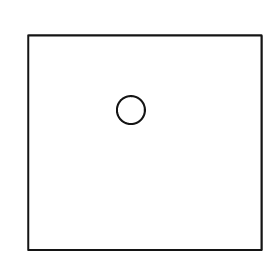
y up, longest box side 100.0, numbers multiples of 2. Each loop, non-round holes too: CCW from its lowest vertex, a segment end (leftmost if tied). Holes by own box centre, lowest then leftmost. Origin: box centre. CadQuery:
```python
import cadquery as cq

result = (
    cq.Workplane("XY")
    .moveTo(-50.0, -46.0)
    .lineTo(50.0, -46.0)
    .lineTo(50.0, 46.0)
    .lineTo(-50.0, 46.0)
    .close()
    .moveTo(-6.0, 14.0)
    .circle(6.0)
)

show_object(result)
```